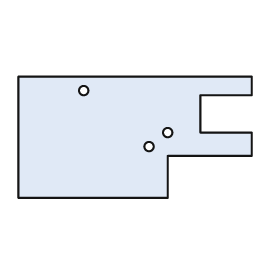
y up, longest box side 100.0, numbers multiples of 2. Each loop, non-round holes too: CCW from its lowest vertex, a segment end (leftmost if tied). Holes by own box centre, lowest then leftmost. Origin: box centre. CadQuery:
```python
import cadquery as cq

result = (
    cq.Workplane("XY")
    .moveTo(-50.0, -26.0)
    .lineTo(14.0, -26.0)
    .lineTo(14.0, -8.0)
    .lineTo(50.0, -8.0)
    .lineTo(50.0, 2.0)
    .lineTo(28.0, 2.0)
    .lineTo(28.0, 18.0)
    .lineTo(50.0, 18.0)
    .lineTo(50.0, 26.0)
    .lineTo(-50.0, 26.0)
    .close()
    .moveTo(6.0, -4.0)
    .circle(2.0)
    .moveTo(14.0, 2.0)
    .circle(2.0)
    .moveTo(-22.0, 20.0)
    .circle(2.0)
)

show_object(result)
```